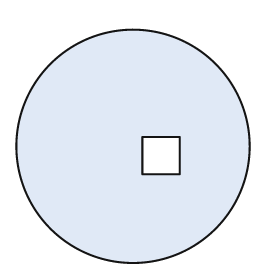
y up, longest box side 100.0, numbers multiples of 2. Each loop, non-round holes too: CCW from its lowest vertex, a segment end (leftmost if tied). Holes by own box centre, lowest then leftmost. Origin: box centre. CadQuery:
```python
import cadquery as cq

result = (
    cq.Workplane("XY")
    .moveTo(0.0, 0.0)
    .circle(50.0)
    .moveTo(4.0, -12.0)
    .lineTo(20.0, -12.0)
    .lineTo(20.0, 4.0)
    .lineTo(4.0, 4.0)
    .close()
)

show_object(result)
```